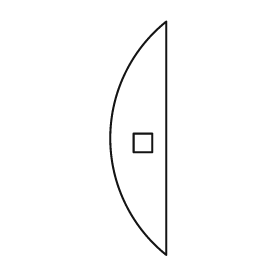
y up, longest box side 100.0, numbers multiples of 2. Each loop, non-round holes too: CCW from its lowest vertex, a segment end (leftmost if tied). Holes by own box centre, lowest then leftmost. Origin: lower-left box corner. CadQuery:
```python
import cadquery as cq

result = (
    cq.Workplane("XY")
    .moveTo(24.0, 0.0)
    .lineTo(24.0, 100.0)
    .threePointArc((0.0, 50.0), (24.0, 0.0))
    .close()
    .moveTo(10.0, 44.0)
    .lineTo(18.0, 44.0)
    .lineTo(18.0, 52.0)
    .lineTo(10.0, 52.0)
    .close()
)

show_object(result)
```